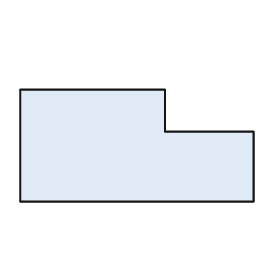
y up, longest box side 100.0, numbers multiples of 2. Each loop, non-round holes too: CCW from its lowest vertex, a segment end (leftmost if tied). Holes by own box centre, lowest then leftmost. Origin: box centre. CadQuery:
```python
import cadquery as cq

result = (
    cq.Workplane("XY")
    .moveTo(-50.0, -24.0)
    .lineTo(50.0, -24.0)
    .lineTo(50.0, 6.0)
    .lineTo(12.0, 6.0)
    .lineTo(12.0, 24.0)
    .lineTo(-50.0, 24.0)
    .close()
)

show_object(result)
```